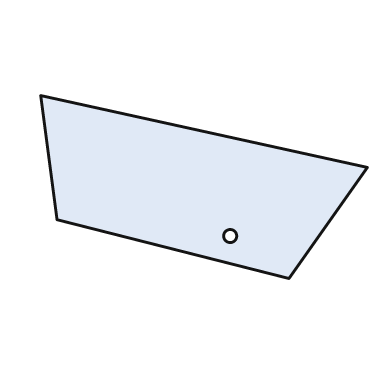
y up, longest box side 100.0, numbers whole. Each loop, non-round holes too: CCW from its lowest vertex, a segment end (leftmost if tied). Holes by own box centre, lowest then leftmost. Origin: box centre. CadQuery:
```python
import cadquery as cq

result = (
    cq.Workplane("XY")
    .moveTo(26.0, -28.0)
    .lineTo(50.0, 6.0)
    .lineTo(-50.0, 28.0)
    .lineTo(-45.0, -10.0)
    .close()
    .moveTo(8.0, -15.0)
    .circle(2.0)
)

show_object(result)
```